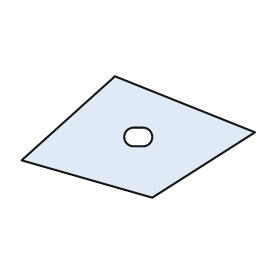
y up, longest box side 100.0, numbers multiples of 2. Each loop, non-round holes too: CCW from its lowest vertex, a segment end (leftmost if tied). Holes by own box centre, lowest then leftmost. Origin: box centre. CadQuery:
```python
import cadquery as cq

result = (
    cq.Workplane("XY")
    .moveTo(6.0, -26.0)
    .lineTo(50.0, 2.0)
    .lineTo(-10.0, 26.0)
    .lineTo(-50.0, -10.0)
    .close()
    .moveTo(-2.0, -4.0)
    .lineTo(2.0, -4.0)
    .threePointArc((6.0, 0.0), (2.0, 4.0))
    .lineTo(-2.0, 4.0)
    .threePointArc((-6.0, 0.0), (-2.0, -4.0))
    .close()
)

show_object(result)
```